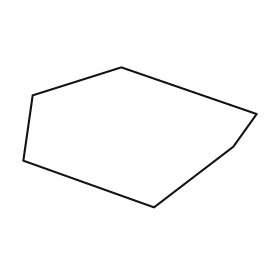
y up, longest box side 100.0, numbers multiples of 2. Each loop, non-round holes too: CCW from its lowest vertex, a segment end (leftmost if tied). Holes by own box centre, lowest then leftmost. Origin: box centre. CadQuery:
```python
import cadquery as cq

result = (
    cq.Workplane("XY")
    .moveTo(6.0, -30.0)
    .lineTo(40.0, -4.0)
    .lineTo(50.0, 10.0)
    .lineTo(-8.0, 30.0)
    .lineTo(-46.0, 18.0)
    .lineTo(-50.0, -10.0)
    .close()
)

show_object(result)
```